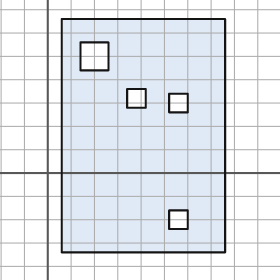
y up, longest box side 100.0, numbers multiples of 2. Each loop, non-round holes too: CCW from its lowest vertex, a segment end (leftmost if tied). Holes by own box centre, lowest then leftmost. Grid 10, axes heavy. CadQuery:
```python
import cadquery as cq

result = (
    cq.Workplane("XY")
    .moveTo(6.0, -34.0)
    .lineTo(76.0, -34.0)
    .lineTo(76.0, 66.0)
    .lineTo(6.0, 66.0)
    .close()
    .moveTo(52.0, -24.0)
    .lineTo(60.0, -24.0)
    .lineTo(60.0, -16.0)
    .lineTo(52.0, -16.0)
    .close()
    .moveTo(52.0, 26.0)
    .lineTo(60.0, 26.0)
    .lineTo(60.0, 34.0)
    .lineTo(52.0, 34.0)
    .close()
    .moveTo(34.0, 28.0)
    .lineTo(42.0, 28.0)
    .lineTo(42.0, 36.0)
    .lineTo(34.0, 36.0)
    .close()
    .moveTo(14.0, 44.0)
    .lineTo(26.0, 44.0)
    .lineTo(26.0, 56.0)
    .lineTo(14.0, 56.0)
    .close()
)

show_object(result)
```